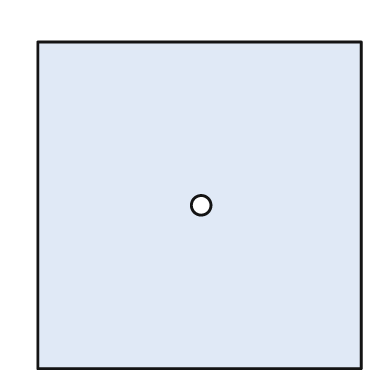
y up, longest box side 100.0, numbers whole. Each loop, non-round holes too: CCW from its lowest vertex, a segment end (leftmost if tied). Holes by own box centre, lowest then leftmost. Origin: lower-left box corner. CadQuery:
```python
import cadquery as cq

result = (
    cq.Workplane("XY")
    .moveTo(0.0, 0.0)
    .lineTo(99.0, 0.0)
    .lineTo(99.0, 100.0)
    .lineTo(0.0, 100.0)
    .close()
    .moveTo(50.0, 50.0)
    .circle(3.0)
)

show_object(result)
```